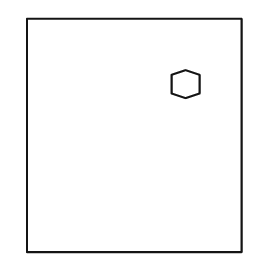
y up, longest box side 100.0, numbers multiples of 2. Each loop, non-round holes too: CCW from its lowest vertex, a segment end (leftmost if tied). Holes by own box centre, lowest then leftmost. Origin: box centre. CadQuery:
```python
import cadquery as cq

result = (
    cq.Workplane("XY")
    .moveTo(-46.0, -50.0)
    .lineTo(46.0, -50.0)
    .lineTo(46.0, 50.0)
    .lineTo(-46.0, 50.0)
    .close()
    .moveTo(22.0, 16.0)
    .lineTo(28.0, 18.0)
    .lineTo(28.0, 26.0)
    .lineTo(22.0, 28.0)
    .lineTo(16.0, 26.0)
    .lineTo(16.0, 18.0)
    .close()
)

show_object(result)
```